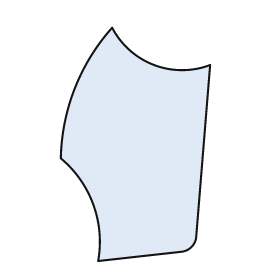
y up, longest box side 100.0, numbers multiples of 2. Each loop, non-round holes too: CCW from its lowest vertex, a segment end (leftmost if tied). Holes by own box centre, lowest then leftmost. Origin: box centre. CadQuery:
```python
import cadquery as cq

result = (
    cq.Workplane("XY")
    .moveTo(-16.0, -50.0)
    .lineTo(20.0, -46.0)
    .threePointArc((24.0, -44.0), (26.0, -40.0))
    .lineTo(32.0, 34.0)
    .threePointArc((8.0, 34.0), (-10.0, 50.0))
    .threePointArc((-26.0, 24.0), (-32.0, -6.0))
    .threePointArc((-18.0, -26.0), (-16.0, -50.0))
    .close()
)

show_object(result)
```